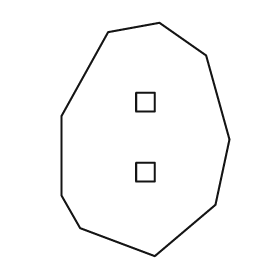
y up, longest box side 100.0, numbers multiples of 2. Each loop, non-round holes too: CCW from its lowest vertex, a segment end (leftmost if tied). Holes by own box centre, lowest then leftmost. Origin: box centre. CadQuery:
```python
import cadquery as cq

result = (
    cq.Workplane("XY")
    .moveTo(4.0, -50.0)
    .lineTo(30.0, -28.0)
    .lineTo(36.0, 0.0)
    .lineTo(26.0, 36.0)
    .lineTo(6.0, 50.0)
    .lineTo(-16.0, 46.0)
    .lineTo(-36.0, 10.0)
    .lineTo(-36.0, -24.0)
    .lineTo(-28.0, -38.0)
    .close()
    .moveTo(-4.0, -18.0)
    .lineTo(4.0, -18.0)
    .lineTo(4.0, -10.0)
    .lineTo(-4.0, -10.0)
    .close()
    .moveTo(-4.0, 12.0)
    .lineTo(4.0, 12.0)
    .lineTo(4.0, 20.0)
    .lineTo(-4.0, 20.0)
    .close()
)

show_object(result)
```